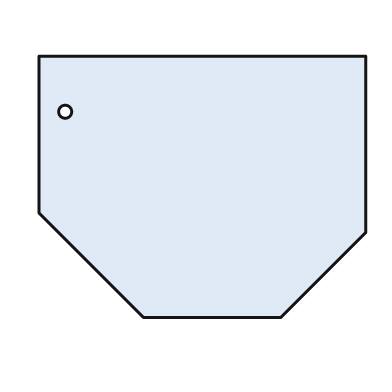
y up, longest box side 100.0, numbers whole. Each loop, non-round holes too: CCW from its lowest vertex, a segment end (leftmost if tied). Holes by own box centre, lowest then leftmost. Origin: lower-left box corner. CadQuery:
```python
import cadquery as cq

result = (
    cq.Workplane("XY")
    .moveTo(32.0, 0.0)
    .lineTo(74.0, 0.0)
    .lineTo(100.0, 26.0)
    .lineTo(100.0, 80.0)
    .lineTo(0.0, 80.0)
    .lineTo(0.0, 32.0)
    .close()
    .moveTo(8.0, 63.0)
    .circle(2.0)
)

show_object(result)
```